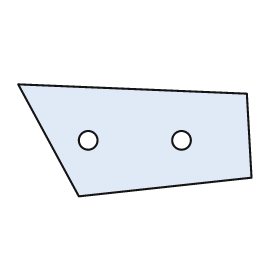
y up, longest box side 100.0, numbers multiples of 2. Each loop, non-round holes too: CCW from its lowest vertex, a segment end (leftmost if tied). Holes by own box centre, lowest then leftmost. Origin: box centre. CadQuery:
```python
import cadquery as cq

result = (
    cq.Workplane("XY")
    .moveTo(-24.0, -24.0)
    .lineTo(50.0, -16.0)
    .lineTo(48.0, 20.0)
    .lineTo(-50.0, 24.0)
    .close()
    .moveTo(-20.0, 0.0)
    .circle(4.0)
    .moveTo(20.0, 0.0)
    .circle(4.0)
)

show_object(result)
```